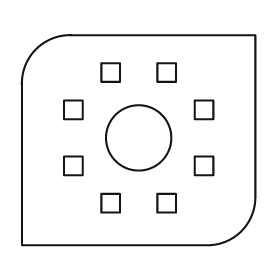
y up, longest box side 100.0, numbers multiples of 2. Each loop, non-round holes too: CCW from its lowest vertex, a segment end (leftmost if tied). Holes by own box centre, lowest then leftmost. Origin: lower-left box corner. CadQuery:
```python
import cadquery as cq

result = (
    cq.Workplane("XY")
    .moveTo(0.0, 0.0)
    .lineTo(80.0, 0.0)
    .threePointArc((94.0, 6.0), (100.0, 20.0))
    .lineTo(100.0, 90.0)
    .lineTo(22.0, 90.0)
    .threePointArc((6.0, 84.0), (0.0, 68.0))
    .close()
    .moveTo(34.0, 14.0)
    .lineTo(42.0, 14.0)
    .lineTo(42.0, 22.0)
    .lineTo(34.0, 22.0)
    .close()
    .moveTo(58.0, 14.0)
    .lineTo(66.0, 14.0)
    .lineTo(66.0, 22.0)
    .lineTo(58.0, 22.0)
    .close()
    .moveTo(18.0, 30.0)
    .lineTo(26.0, 30.0)
    .lineTo(26.0, 38.0)
    .lineTo(18.0, 38.0)
    .close()
    .moveTo(74.0, 30.0)
    .lineTo(82.0, 30.0)
    .lineTo(82.0, 38.0)
    .lineTo(74.0, 38.0)
    .close()
    .moveTo(50.0, 46.0)
    .circle(14.0)
    .moveTo(18.0, 54.0)
    .lineTo(26.0, 54.0)
    .lineTo(26.0, 62.0)
    .lineTo(18.0, 62.0)
    .close()
    .moveTo(74.0, 54.0)
    .lineTo(82.0, 54.0)
    .lineTo(82.0, 62.0)
    .lineTo(74.0, 62.0)
    .close()
    .moveTo(34.0, 70.0)
    .lineTo(42.0, 70.0)
    .lineTo(42.0, 78.0)
    .lineTo(34.0, 78.0)
    .close()
    .moveTo(58.0, 70.0)
    .lineTo(66.0, 70.0)
    .lineTo(66.0, 78.0)
    .lineTo(58.0, 78.0)
    .close()
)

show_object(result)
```